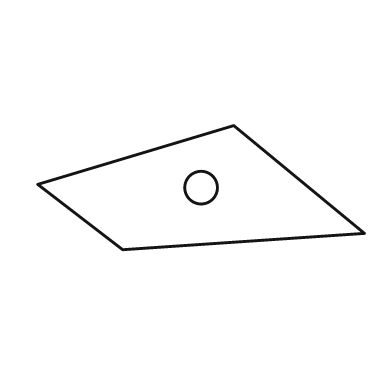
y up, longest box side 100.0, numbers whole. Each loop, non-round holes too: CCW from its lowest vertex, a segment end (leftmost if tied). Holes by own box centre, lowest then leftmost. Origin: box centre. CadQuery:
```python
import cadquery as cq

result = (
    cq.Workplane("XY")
    .moveTo(-24.0, -19.0)
    .lineTo(50.0, -14.0)
    .lineTo(10.0, 19.0)
    .lineTo(-50.0, 1.0)
    .close()
    .moveTo(0.0, 0.0)
    .circle(5.0)
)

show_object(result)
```